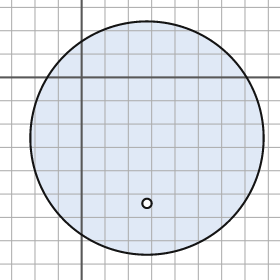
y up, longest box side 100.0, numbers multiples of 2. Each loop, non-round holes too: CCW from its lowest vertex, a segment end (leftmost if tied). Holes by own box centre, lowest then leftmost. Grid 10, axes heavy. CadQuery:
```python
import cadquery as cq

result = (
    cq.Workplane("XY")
    .moveTo(28.0, -26.0)
    .circle(50.0)
    .moveTo(28.0, -54.0)
    .circle(2.0)
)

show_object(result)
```